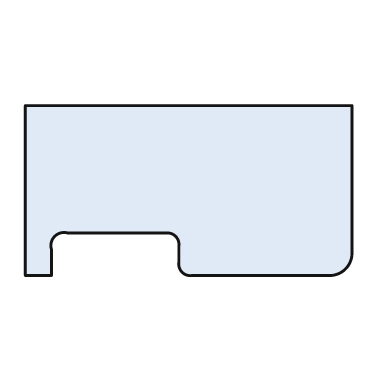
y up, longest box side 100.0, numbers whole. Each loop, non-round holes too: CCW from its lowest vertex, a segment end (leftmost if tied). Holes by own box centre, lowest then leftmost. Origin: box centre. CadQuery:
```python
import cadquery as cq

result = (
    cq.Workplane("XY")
    .moveTo(-50.0, -26.0)
    .lineTo(-42.0, -26.0)
    .lineTo(-42.0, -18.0)
    .threePointArc((-41.0, -14.0), (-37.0, -13.0))
    .lineTo(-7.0, -13.0)
    .threePointArc((-4.0, -14.0), (-3.0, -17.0))
    .lineTo(-3.0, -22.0)
    .threePointArc((-2.0, -25.0), (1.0, -26.0))
    .lineTo(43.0, -26.0)
    .threePointArc((48.0, -24.0), (50.0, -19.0))
    .lineTo(50.0, 26.0)
    .lineTo(-50.0, 26.0)
    .close()
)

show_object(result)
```